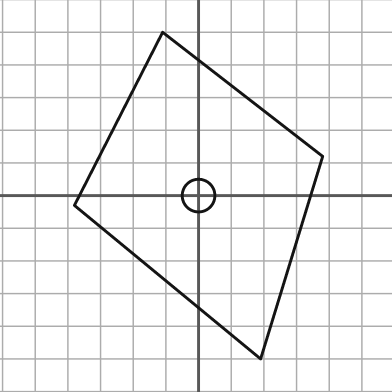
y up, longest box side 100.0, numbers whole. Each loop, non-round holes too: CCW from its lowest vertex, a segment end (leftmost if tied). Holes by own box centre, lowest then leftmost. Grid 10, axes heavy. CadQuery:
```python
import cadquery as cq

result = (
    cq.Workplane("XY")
    .moveTo(19.0, -50.0)
    .lineTo(38.0, 12.0)
    .lineTo(-11.0, 50.0)
    .lineTo(-38.0, -3.0)
    .close()
    .moveTo(0.0, 0.0)
    .circle(5.0)
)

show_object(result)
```